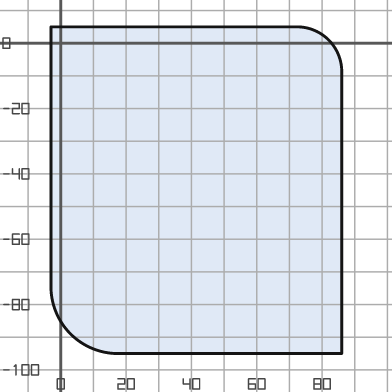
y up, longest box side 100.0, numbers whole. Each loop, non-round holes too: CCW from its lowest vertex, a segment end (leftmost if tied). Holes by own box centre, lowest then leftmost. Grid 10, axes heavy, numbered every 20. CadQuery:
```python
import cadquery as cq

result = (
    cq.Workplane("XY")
    .moveTo(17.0, -95.0)
    .lineTo(86.0, -95.0)
    .lineTo(86.0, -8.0)
    .threePointArc((82.0, 1.0), (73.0, 5.0))
    .lineTo(-3.0, 5.0)
    .lineTo(-3.0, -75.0)
    .threePointArc((3.0, -89.0), (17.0, -95.0))
    .close()
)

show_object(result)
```